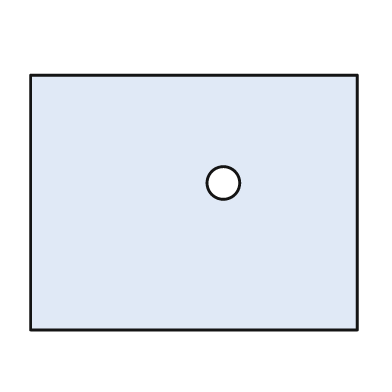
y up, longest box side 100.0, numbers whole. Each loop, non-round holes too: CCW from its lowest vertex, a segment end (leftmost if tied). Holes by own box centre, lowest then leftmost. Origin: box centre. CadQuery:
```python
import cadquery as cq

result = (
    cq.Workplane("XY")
    .moveTo(-50.0, -39.0)
    .lineTo(50.0, -39.0)
    .lineTo(50.0, 39.0)
    .lineTo(-50.0, 39.0)
    .close()
    .moveTo(9.0, 6.0)
    .circle(5.0)
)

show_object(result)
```